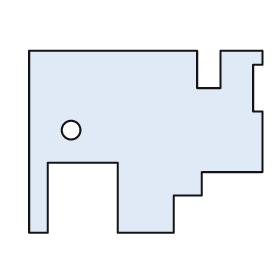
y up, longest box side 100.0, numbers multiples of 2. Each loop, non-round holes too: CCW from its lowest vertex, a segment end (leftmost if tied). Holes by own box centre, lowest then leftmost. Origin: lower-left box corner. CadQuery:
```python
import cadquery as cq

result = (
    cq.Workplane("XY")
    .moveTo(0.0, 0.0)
    .lineTo(8.0, 0.0)
    .lineTo(8.0, 30.0)
    .lineTo(38.0, 30.0)
    .lineTo(38.0, 0.0)
    .lineTo(62.0, 0.0)
    .lineTo(62.0, 16.0)
    .lineTo(74.0, 16.0)
    .lineTo(74.0, 26.0)
    .lineTo(100.0, 26.0)
    .lineTo(100.0, 52.0)
    .lineTo(96.0, 52.0)
    .lineTo(96.0, 72.0)
    .lineTo(100.0, 72.0)
    .lineTo(100.0, 78.0)
    .lineTo(82.0, 78.0)
    .lineTo(82.0, 62.0)
    .lineTo(72.0, 62.0)
    .lineTo(72.0, 78.0)
    .lineTo(0.0, 78.0)
    .close()
    .moveTo(18.0, 44.0)
    .circle(4.0)
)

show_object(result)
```